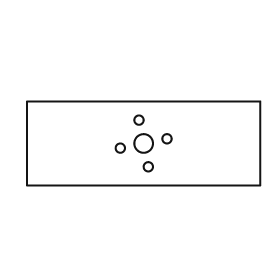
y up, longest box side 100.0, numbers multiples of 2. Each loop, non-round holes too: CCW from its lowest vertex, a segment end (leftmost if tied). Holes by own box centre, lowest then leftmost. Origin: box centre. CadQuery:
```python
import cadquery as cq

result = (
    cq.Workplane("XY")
    .moveTo(-50.0, -18.0)
    .lineTo(50.0, -18.0)
    .lineTo(50.0, 18.0)
    .lineTo(-50.0, 18.0)
    .close()
    .moveTo(2.0, -10.0)
    .circle(2.0)
    .moveTo(-10.0, -2.0)
    .circle(2.0)
    .moveTo(0.0, 0.0)
    .circle(4.0)
    .moveTo(10.0, 2.0)
    .circle(2.0)
    .moveTo(-2.0, 10.0)
    .circle(2.0)
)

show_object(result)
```